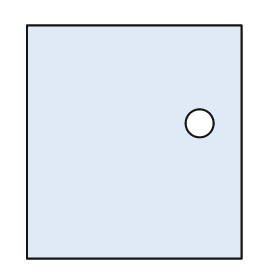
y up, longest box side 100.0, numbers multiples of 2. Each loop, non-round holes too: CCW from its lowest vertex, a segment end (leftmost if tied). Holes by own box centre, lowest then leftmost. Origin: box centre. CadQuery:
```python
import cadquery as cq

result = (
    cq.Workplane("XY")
    .moveTo(-46.0, -50.0)
    .lineTo(46.0, -50.0)
    .lineTo(46.0, 50.0)
    .lineTo(-46.0, 50.0)
    .close()
    .moveTo(28.0, 8.0)
    .circle(6.0)
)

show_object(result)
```